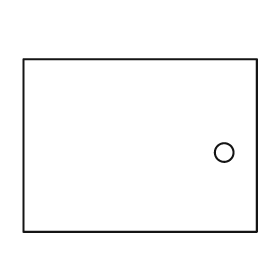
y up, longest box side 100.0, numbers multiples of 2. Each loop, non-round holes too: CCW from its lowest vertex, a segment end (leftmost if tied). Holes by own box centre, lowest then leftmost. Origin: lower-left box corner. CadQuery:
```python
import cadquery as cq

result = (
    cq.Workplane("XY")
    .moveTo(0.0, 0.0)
    .lineTo(100.0, 0.0)
    .lineTo(100.0, 74.0)
    .lineTo(0.0, 74.0)
    .close()
    .moveTo(86.0, 34.0)
    .circle(4.0)
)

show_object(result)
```